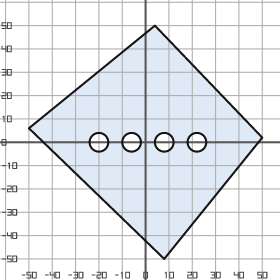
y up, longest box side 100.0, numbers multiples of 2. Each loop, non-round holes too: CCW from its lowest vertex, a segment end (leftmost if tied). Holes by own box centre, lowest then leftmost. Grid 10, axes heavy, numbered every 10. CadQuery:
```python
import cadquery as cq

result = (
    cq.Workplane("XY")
    .moveTo(8.0, -50.0)
    .lineTo(50.0, 2.0)
    .lineTo(4.0, 50.0)
    .lineTo(-50.0, 6.0)
    .close()
    .moveTo(-20.0, 0.0)
    .circle(4.0)
    .moveTo(-6.0, 0.0)
    .circle(4.0)
    .moveTo(8.0, 0.0)
    .circle(4.0)
    .moveTo(22.0, 0.0)
    .circle(4.0)
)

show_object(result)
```